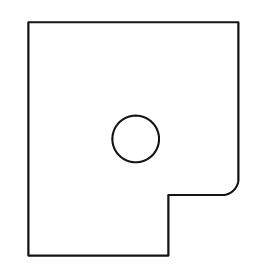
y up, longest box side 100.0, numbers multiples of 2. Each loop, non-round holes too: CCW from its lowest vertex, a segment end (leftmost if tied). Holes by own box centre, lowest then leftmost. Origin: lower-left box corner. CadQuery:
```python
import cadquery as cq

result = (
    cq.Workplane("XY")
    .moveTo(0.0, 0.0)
    .lineTo(60.0, 0.0)
    .lineTo(60.0, 26.0)
    .lineTo(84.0, 26.0)
    .threePointArc((88.0, 28.0), (90.0, 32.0))
    .lineTo(90.0, 100.0)
    .lineTo(0.0, 100.0)
    .close()
    .moveTo(46.0, 50.0)
    .circle(10.0)
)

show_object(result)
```